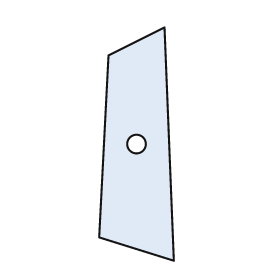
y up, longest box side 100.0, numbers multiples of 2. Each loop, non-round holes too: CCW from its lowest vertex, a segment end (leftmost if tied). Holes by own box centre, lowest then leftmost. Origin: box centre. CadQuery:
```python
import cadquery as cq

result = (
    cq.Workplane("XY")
    .moveTo(16.0, -50.0)
    .lineTo(12.0, 50.0)
    .lineTo(-12.0, 38.0)
    .lineTo(-16.0, -40.0)
    .close()
    .moveTo(0.0, 0.0)
    .circle(4.0)
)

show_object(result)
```